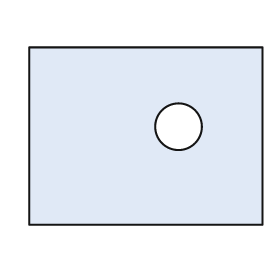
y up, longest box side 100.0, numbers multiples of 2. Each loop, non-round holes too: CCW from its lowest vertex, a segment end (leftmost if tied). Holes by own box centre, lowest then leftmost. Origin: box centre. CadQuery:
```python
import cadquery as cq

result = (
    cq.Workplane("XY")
    .moveTo(-50.0, -38.0)
    .lineTo(50.0, -38.0)
    .lineTo(50.0, 38.0)
    .lineTo(-50.0, 38.0)
    .close()
    .moveTo(14.0, 4.0)
    .circle(10.0)
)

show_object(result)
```